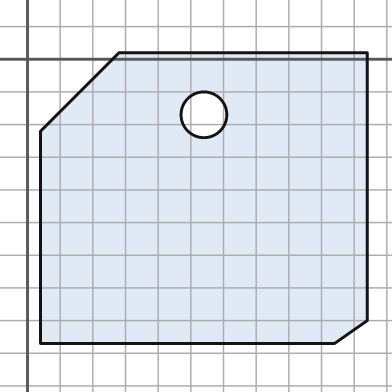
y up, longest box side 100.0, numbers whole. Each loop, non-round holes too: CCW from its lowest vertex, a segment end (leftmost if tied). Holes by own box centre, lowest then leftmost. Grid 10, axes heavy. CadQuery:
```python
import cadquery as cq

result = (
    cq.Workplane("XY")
    .moveTo(4.0, -87.0)
    .lineTo(94.0, -87.0)
    .lineTo(104.0, -80.0)
    .lineTo(104.0, 2.0)
    .lineTo(28.0, 2.0)
    .lineTo(4.0, -22.0)
    .close()
    .moveTo(54.0, -17.0)
    .circle(7.0)
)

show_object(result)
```